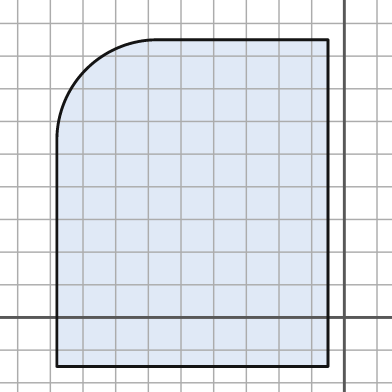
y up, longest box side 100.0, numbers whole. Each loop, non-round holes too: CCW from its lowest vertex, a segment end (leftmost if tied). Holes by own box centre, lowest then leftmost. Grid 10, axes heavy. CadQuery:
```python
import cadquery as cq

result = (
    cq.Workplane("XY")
    .moveTo(-88.0, -15.0)
    .lineTo(-5.0, -15.0)
    .lineTo(-5.0, 85.0)
    .lineTo(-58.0, 85.0)
    .threePointArc((-79.0, 76.0), (-88.0, 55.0))
    .close()
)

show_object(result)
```